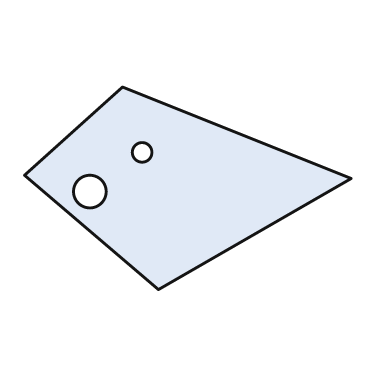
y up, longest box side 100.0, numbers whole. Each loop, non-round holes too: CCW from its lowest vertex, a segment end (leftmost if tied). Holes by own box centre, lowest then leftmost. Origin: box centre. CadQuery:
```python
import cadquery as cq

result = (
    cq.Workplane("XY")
    .moveTo(-9.0, -31.0)
    .lineTo(50.0, 3.0)
    .lineTo(-20.0, 31.0)
    .lineTo(-50.0, 4.0)
    .close()
    .moveTo(-30.0, -1.0)
    .circle(5.0)
    .moveTo(-14.0, 11.0)
    .circle(3.0)
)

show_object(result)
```